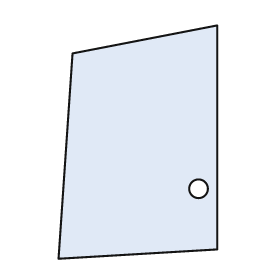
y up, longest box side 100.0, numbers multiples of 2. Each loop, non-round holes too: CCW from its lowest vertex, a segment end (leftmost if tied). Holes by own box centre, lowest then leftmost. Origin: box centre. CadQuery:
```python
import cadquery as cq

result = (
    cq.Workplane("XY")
    .moveTo(-34.0, -50.0)
    .lineTo(34.0, -46.0)
    .lineTo(34.0, 50.0)
    .lineTo(-28.0, 38.0)
    .close()
    .moveTo(26.0, -20.0)
    .circle(4.0)
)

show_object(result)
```